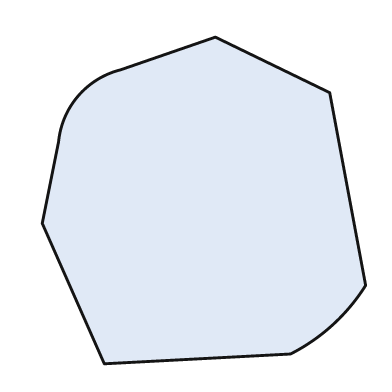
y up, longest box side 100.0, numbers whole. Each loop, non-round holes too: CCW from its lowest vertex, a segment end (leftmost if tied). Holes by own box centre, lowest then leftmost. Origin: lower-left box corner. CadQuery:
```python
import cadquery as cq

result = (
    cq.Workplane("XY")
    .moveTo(19.0, 0.0)
    .lineTo(76.0, 3.0)
    .threePointArc((89.0, 12.0), (99.0, 24.0))
    .lineTo(88.0, 83.0)
    .lineTo(53.0, 100.0)
    .lineTo(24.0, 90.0)
    .threePointArc((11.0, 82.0), (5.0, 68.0))
    .lineTo(0.0, 43.0)
    .close()
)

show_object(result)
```